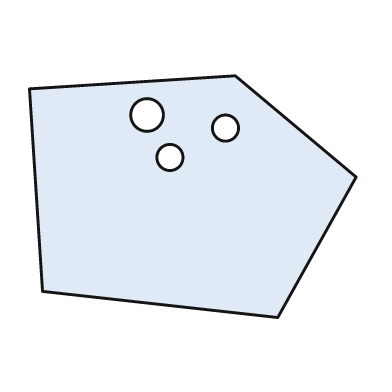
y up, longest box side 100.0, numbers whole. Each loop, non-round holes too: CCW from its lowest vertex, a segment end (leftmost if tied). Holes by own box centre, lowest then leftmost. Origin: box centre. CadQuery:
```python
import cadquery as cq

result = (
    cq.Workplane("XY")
    .moveTo(26.0, -37.0)
    .lineTo(50.0, 6.0)
    .lineTo(13.0, 37.0)
    .lineTo(-50.0, 33.0)
    .lineTo(-46.0, -29.0)
    .close()
    .moveTo(-7.0, 12.0)
    .circle(4.0)
    .moveTo(10.0, 21.0)
    .circle(4.0)
    .moveTo(-14.0, 25.0)
    .circle(5.0)
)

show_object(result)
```